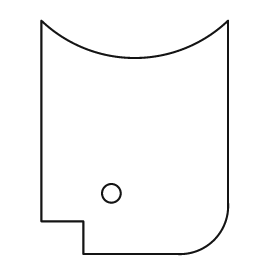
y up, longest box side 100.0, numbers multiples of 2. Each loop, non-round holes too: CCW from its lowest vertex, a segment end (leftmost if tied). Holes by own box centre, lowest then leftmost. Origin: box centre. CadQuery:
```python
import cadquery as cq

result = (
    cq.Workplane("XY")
    .moveTo(-22.0, -50.0)
    .lineTo(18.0, -50.0)
    .threePointArc((34.0, -44.0), (40.0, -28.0))
    .lineTo(40.0, 50.0)
    .threePointArc((0.0, 34.0), (-40.0, 50.0))
    .lineTo(-40.0, -36.0)
    .lineTo(-22.0, -36.0)
    .close()
    .moveTo(-10.0, -24.0)
    .circle(4.0)
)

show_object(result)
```